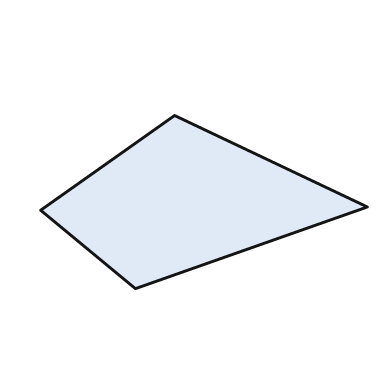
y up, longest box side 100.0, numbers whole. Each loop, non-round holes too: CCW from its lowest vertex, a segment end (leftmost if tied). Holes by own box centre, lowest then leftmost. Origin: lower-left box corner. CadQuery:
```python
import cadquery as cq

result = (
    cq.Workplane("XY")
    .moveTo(29.0, 0.0)
    .lineTo(100.0, 25.0)
    .lineTo(41.0, 53.0)
    .lineTo(0.0, 24.0)
    .close()
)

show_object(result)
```